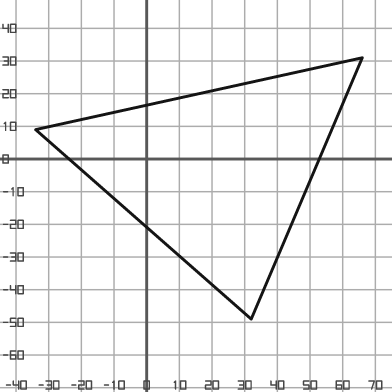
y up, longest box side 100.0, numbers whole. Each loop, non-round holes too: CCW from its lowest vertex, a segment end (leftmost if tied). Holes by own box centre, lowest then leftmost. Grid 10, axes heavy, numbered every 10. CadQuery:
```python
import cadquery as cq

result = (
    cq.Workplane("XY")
    .moveTo(32.0, -49.0)
    .lineTo(66.0, 31.0)
    .lineTo(-34.0, 9.0)
    .close()
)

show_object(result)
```